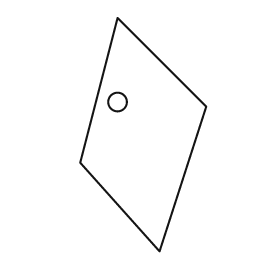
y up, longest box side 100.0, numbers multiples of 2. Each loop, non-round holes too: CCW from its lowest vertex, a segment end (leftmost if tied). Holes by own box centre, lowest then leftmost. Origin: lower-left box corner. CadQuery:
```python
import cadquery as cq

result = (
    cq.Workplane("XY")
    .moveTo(34.0, 0.0)
    .lineTo(54.0, 62.0)
    .lineTo(16.0, 100.0)
    .lineTo(0.0, 38.0)
    .close()
    .moveTo(16.0, 64.0)
    .circle(4.0)
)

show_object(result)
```